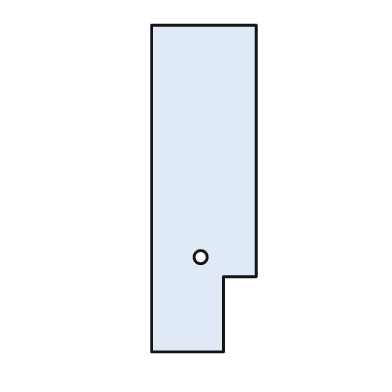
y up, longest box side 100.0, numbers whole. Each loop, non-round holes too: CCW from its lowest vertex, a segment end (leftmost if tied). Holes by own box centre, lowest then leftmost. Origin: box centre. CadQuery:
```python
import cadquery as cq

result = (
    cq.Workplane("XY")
    .moveTo(-16.0, -50.0)
    .lineTo(6.0, -50.0)
    .lineTo(6.0, -27.0)
    .lineTo(16.0, -27.0)
    .lineTo(16.0, 50.0)
    .lineTo(-16.0, 50.0)
    .close()
    .moveTo(-1.0, -21.0)
    .circle(2.0)
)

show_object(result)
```